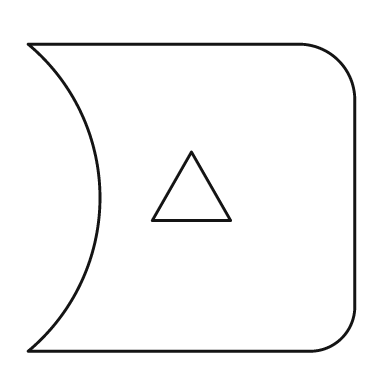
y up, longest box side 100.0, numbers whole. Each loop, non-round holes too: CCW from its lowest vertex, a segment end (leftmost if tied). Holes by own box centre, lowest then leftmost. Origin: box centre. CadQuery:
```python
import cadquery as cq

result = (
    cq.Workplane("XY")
    .moveTo(-50.0, -47.0)
    .lineTo(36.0, -47.0)
    .threePointArc((46.0, -43.0), (50.0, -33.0))
    .lineTo(50.0, 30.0)
    .threePointArc((45.0, 42.0), (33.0, 47.0))
    .lineTo(-50.0, 47.0)
    .threePointArc((-28.0, 0.0), (-50.0, -47.0))
    .close()
    .moveTo(-12.0, -7.0)
    .lineTo(12.0, -7.0)
    .lineTo(0.0, 14.0)
    .close()
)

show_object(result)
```